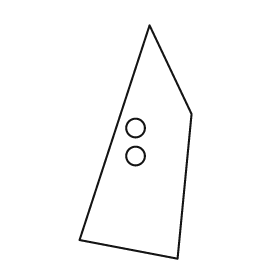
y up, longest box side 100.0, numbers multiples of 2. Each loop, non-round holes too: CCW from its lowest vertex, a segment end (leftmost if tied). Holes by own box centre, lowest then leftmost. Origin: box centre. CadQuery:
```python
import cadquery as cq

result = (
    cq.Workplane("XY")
    .moveTo(18.0, -50.0)
    .lineTo(24.0, 12.0)
    .lineTo(6.0, 50.0)
    .lineTo(-24.0, -42.0)
    .close()
    .moveTo(0.0, -6.0)
    .circle(4.0)
    .moveTo(0.0, 6.0)
    .circle(4.0)
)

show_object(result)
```